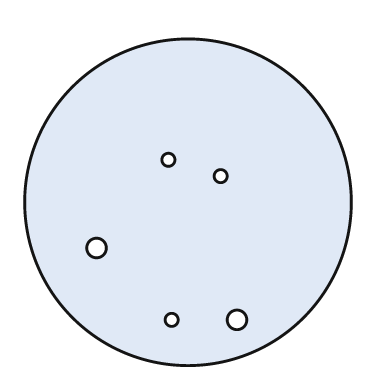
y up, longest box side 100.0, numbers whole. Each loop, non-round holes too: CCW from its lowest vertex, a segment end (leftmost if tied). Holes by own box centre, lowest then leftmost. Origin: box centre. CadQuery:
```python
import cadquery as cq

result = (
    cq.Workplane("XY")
    .moveTo(0.0, 0.0)
    .circle(50.0)
    .moveTo(-5.0, -36.0)
    .circle(2.0)
    .moveTo(15.0, -36.0)
    .circle(3.0)
    .moveTo(-28.0, -14.0)
    .circle(3.0)
    .moveTo(10.0, 8.0)
    .circle(2.0)
    .moveTo(-6.0, 13.0)
    .circle(2.0)
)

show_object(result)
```